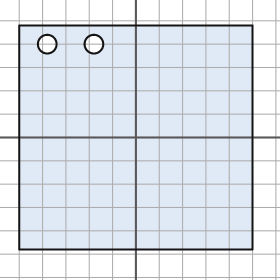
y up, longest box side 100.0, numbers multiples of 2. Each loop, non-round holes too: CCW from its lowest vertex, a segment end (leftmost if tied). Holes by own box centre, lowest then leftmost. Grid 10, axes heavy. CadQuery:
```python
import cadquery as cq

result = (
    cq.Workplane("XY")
    .moveTo(-50.0, -48.0)
    .lineTo(50.0, -48.0)
    .lineTo(50.0, 48.0)
    .lineTo(-50.0, 48.0)
    .close()
    .moveTo(-38.0, 40.0)
    .circle(4.0)
    .moveTo(-18.0, 40.0)
    .circle(4.0)
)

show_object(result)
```